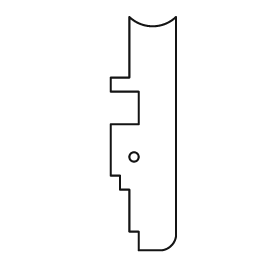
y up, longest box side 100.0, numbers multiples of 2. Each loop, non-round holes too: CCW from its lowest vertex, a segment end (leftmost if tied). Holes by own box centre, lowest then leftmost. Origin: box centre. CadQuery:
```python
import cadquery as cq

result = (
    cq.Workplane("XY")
    .moveTo(-2.0, -50.0)
    .lineTo(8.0, -50.0)
    .threePointArc((12.0, -48.0), (14.0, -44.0))
    .lineTo(14.0, 50.0)
    .threePointArc((4.0, 46.0), (-6.0, 50.0))
    .lineTo(-6.0, 24.0)
    .lineTo(-14.0, 24.0)
    .lineTo(-14.0, 18.0)
    .lineTo(-2.0, 18.0)
    .lineTo(-2.0, 4.0)
    .lineTo(-14.0, 4.0)
    .lineTo(-14.0, -18.0)
    .lineTo(-10.0, -18.0)
    .lineTo(-10.0, -24.0)
    .lineTo(-6.0, -24.0)
    .lineTo(-6.0, -42.0)
    .lineTo(-2.0, -42.0)
    .close()
    .moveTo(-4.0, -10.0)
    .circle(2.0)
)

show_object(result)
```